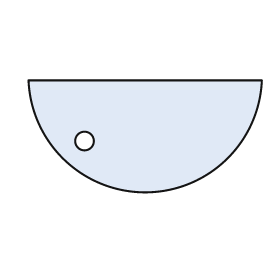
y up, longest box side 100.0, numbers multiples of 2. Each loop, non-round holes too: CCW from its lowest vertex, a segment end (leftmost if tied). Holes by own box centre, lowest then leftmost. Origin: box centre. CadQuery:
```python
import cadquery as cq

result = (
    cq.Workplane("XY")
    .moveTo(-50.0, 24.0)
    .threePointArc((0.0, -24.0), (50.0, 24.0))
    .close()
    .moveTo(-26.0, -2.0)
    .circle(4.0)
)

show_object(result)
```